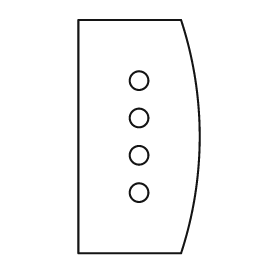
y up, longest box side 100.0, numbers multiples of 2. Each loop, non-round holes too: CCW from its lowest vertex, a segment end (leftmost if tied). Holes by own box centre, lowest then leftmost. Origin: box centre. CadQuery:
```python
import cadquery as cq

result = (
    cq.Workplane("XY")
    .moveTo(-26.0, -50.0)
    .lineTo(18.0, -50.0)
    .threePointArc((26.0, 0.0), (18.0, 50.0))
    .lineTo(-26.0, 50.0)
    .close()
    .moveTo(0.0, -24.0)
    .circle(4.0)
    .moveTo(0.0, -8.0)
    .circle(4.0)
    .moveTo(0.0, 8.0)
    .circle(4.0)
    .moveTo(0.0, 24.0)
    .circle(4.0)
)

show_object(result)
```